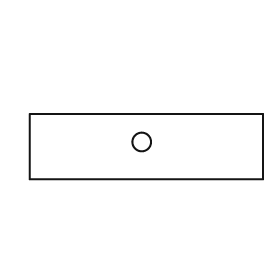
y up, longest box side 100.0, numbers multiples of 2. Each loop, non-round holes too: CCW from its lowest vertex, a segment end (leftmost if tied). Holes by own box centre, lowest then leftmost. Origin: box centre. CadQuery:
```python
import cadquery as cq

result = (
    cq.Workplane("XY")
    .moveTo(-50.0, -14.0)
    .lineTo(50.0, -14.0)
    .lineTo(50.0, 14.0)
    .lineTo(-50.0, 14.0)
    .close()
    .moveTo(-2.0, 2.0)
    .circle(4.0)
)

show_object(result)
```